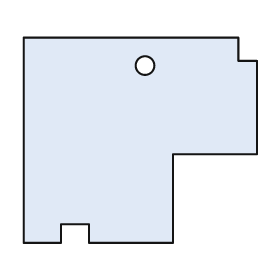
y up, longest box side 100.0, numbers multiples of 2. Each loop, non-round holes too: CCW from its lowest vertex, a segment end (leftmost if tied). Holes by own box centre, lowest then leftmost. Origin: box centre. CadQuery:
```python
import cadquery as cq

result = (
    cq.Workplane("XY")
    .moveTo(-50.0, -44.0)
    .lineTo(-34.0, -44.0)
    .lineTo(-34.0, -36.0)
    .lineTo(-22.0, -36.0)
    .lineTo(-22.0, -44.0)
    .lineTo(14.0, -44.0)
    .lineTo(14.0, -6.0)
    .lineTo(50.0, -6.0)
    .lineTo(50.0, 34.0)
    .lineTo(42.0, 34.0)
    .lineTo(42.0, 44.0)
    .lineTo(-50.0, 44.0)
    .close()
    .moveTo(2.0, 32.0)
    .circle(4.0)
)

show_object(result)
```